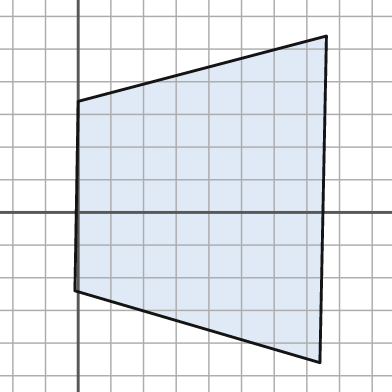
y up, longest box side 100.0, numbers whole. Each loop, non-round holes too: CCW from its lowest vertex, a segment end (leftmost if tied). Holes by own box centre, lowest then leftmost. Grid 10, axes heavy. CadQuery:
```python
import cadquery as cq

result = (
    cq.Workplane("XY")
    .moveTo(74.0, -46.0)
    .lineTo(76.0, 54.0)
    .lineTo(0.0, 34.0)
    .lineTo(-1.0, -24.0)
    .close()
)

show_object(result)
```